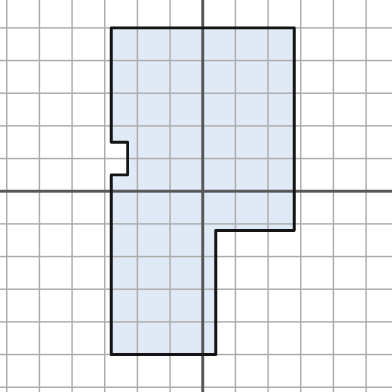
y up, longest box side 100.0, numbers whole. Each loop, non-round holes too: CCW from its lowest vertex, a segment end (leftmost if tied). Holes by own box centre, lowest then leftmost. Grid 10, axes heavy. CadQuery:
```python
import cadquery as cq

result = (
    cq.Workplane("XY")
    .moveTo(-28.0, -50.0)
    .lineTo(4.0, -50.0)
    .lineTo(4.0, -12.0)
    .lineTo(28.0, -12.0)
    .lineTo(28.0, 50.0)
    .lineTo(-28.0, 50.0)
    .lineTo(-28.0, 15.0)
    .lineTo(-23.0, 15.0)
    .lineTo(-23.0, 5.0)
    .lineTo(-28.0, 5.0)
    .close()
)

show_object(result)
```